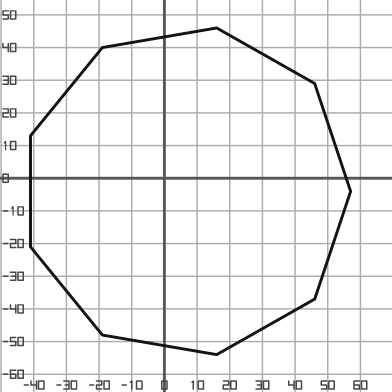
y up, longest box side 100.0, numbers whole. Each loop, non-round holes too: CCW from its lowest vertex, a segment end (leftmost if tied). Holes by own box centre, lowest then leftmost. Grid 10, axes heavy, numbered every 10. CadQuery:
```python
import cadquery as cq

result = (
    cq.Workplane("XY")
    .moveTo(16.0, -54.0)
    .lineTo(46.0, -37.0)
    .lineTo(57.0, -4.0)
    .lineTo(46.0, 29.0)
    .lineTo(16.0, 46.0)
    .lineTo(-19.0, 40.0)
    .lineTo(-41.0, 13.0)
    .lineTo(-41.0, -21.0)
    .lineTo(-19.0, -48.0)
    .close()
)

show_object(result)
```